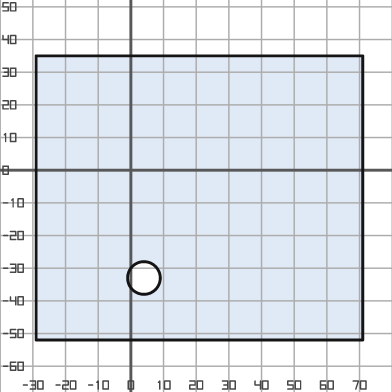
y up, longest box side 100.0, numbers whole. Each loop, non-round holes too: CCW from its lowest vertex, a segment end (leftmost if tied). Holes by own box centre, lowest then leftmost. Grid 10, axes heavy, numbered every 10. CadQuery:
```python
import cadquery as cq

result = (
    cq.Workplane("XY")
    .moveTo(-29.0, -52.0)
    .lineTo(71.0, -52.0)
    .lineTo(71.0, 35.0)
    .lineTo(-29.0, 35.0)
    .close()
    .moveTo(4.0, -33.0)
    .circle(5.0)
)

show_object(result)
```